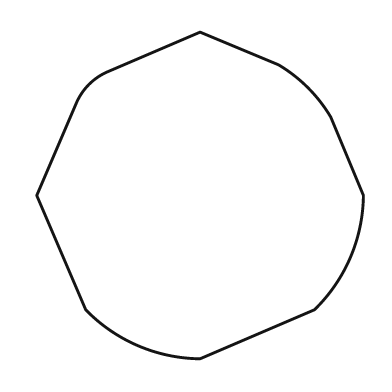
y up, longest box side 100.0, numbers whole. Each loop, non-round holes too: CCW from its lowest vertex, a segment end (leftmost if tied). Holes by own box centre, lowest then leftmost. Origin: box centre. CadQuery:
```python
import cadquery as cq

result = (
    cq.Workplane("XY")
    .moveTo(0.0, -50.0)
    .lineTo(35.0, -35.0)
    .threePointArc((46.0, -19.0), (50.0, 0.0))
    .lineTo(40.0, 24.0)
    .threePointArc((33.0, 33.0), (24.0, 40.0))
    .lineTo(0.0, 50.0)
    .lineTo(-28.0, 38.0)
    .threePointArc((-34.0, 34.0), (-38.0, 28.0))
    .lineTo(-50.0, 0.0)
    .lineTo(-35.0, -35.0)
    .threePointArc((-19.0, -46.0), (0.0, -50.0))
    .close()
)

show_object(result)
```